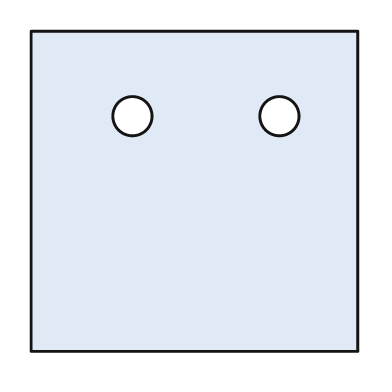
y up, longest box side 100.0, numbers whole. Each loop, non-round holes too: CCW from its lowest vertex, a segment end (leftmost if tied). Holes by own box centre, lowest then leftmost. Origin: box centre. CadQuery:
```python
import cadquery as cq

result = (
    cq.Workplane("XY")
    .moveTo(-50.0, -49.0)
    .lineTo(50.0, -49.0)
    .lineTo(50.0, 49.0)
    .lineTo(-50.0, 49.0)
    .close()
    .moveTo(-19.0, 23.0)
    .circle(6.0)
    .moveTo(26.0, 23.0)
    .circle(6.0)
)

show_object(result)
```